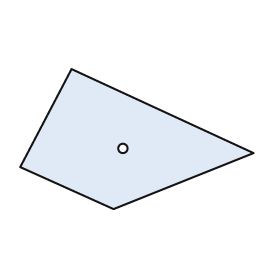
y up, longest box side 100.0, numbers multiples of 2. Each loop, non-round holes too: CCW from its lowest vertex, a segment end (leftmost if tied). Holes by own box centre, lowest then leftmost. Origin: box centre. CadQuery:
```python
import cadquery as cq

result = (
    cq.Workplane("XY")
    .moveTo(-10.0, -30.0)
    .lineTo(50.0, -6.0)
    .lineTo(-28.0, 30.0)
    .lineTo(-50.0, -12.0)
    .close()
    .moveTo(-6.0, -4.0)
    .circle(2.0)
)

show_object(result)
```